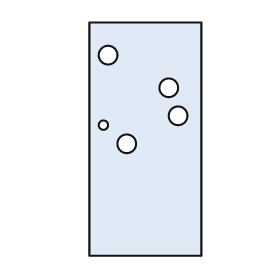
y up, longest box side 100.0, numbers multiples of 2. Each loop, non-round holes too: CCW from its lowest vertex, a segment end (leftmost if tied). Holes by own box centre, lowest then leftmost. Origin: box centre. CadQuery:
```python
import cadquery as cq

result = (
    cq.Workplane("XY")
    .moveTo(-24.0, -50.0)
    .lineTo(24.0, -50.0)
    .lineTo(24.0, 50.0)
    .lineTo(-24.0, 50.0)
    .close()
    .moveTo(-8.0, -2.0)
    .circle(4.0)
    .moveTo(-18.0, 6.0)
    .circle(2.0)
    .moveTo(14.0, 10.0)
    .circle(4.0)
    .moveTo(10.0, 22.0)
    .circle(4.0)
    .moveTo(-16.0, 36.0)
    .circle(4.0)
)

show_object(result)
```